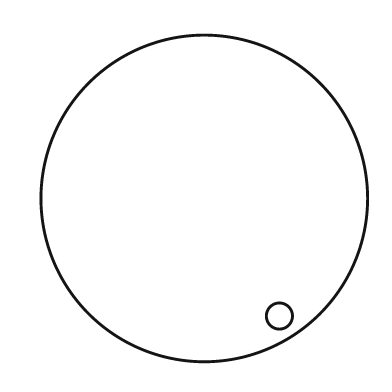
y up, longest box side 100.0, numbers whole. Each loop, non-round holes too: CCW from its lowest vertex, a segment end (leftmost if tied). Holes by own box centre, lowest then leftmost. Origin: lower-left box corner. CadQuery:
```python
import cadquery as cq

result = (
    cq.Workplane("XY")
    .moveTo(50.0, 50.0)
    .circle(50.0)
    .moveTo(73.0, 14.0)
    .circle(4.0)
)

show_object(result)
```